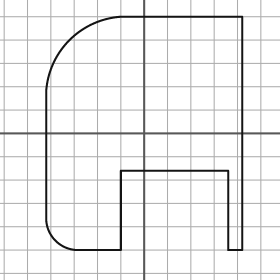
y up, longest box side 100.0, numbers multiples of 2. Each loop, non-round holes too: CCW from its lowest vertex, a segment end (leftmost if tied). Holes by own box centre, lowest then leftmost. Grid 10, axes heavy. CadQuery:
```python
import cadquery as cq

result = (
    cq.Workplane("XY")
    .moveTo(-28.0, -50.0)
    .lineTo(-10.0, -50.0)
    .lineTo(-10.0, -16.0)
    .lineTo(36.0, -16.0)
    .lineTo(36.0, -50.0)
    .lineTo(42.0, -50.0)
    .lineTo(42.0, 50.0)
    .lineTo(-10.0, 50.0)
    .threePointArc((-32.0, 40.0), (-42.0, 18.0))
    .lineTo(-42.0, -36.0)
    .threePointArc((-38.0, -46.0), (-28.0, -50.0))
    .close()
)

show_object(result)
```